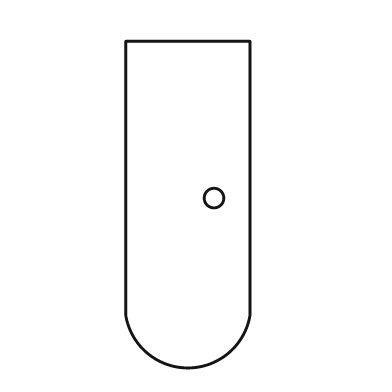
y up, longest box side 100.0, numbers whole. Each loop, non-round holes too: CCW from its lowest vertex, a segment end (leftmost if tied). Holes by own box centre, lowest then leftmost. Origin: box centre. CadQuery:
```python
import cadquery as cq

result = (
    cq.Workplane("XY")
    .moveTo(-19.0, -34.0)
    .threePointArc((0.0, -50.0), (19.0, -34.0))
    .lineTo(19.0, 50.0)
    .lineTo(-19.0, 50.0)
    .close()
    .moveTo(8.0, 2.0)
    .circle(3.0)
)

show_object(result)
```